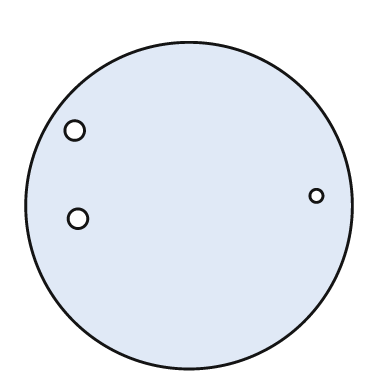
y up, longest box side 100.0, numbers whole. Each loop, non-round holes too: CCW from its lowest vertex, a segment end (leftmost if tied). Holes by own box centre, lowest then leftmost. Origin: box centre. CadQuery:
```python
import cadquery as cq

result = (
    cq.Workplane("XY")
    .moveTo(0.0, 0.0)
    .circle(50.0)
    .moveTo(-34.0, -4.0)
    .circle(3.0)
    .moveTo(39.0, 3.0)
    .circle(2.0)
    .moveTo(-35.0, 23.0)
    .circle(3.0)
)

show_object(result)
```